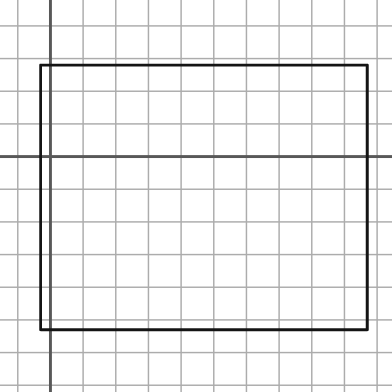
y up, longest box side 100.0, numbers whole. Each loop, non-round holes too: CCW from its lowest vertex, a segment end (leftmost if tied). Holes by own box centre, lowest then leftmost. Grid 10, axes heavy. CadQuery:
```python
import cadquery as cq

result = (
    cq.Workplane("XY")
    .moveTo(-3.0, -53.0)
    .lineTo(97.0, -53.0)
    .lineTo(97.0, 28.0)
    .lineTo(-3.0, 28.0)
    .close()
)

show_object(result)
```